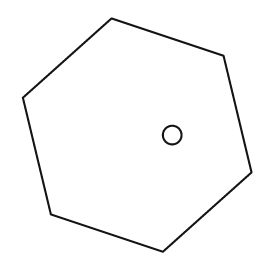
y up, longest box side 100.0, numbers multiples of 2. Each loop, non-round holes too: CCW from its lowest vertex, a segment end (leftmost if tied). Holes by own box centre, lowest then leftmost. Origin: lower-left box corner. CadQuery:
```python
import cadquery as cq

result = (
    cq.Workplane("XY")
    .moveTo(60.0, 0.0)
    .lineTo(98.0, 34.0)
    .lineTo(86.0, 84.0)
    .lineTo(38.0, 100.0)
    .lineTo(0.0, 66.0)
    .lineTo(12.0, 16.0)
    .close()
    .moveTo(64.0, 50.0)
    .circle(4.0)
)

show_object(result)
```